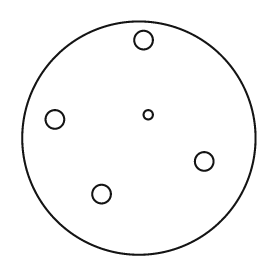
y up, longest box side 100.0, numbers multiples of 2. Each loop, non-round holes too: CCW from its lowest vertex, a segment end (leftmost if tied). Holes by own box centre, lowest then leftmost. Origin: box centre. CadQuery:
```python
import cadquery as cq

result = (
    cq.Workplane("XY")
    .moveTo(0.0, 0.0)
    .circle(50.0)
    .moveTo(-16.0, -24.0)
    .circle(4.0)
    .moveTo(28.0, -10.0)
    .circle(4.0)
    .moveTo(-36.0, 8.0)
    .circle(4.0)
    .moveTo(4.0, 10.0)
    .circle(2.0)
    .moveTo(2.0, 42.0)
    .circle(4.0)
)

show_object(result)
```